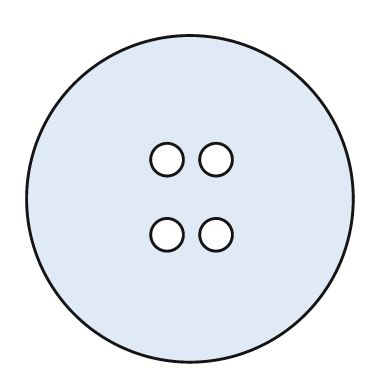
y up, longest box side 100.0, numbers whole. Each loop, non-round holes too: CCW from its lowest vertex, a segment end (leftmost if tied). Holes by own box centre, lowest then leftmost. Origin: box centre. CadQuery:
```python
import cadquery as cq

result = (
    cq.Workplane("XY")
    .moveTo(0.0, 0.0)
    .circle(50.0)
    .moveTo(-7.0, -11.0)
    .circle(5.0)
    .moveTo(8.0, -11.0)
    .circle(5.0)
    .moveTo(-7.0, 12.0)
    .circle(5.0)
    .moveTo(8.0, 12.0)
    .circle(5.0)
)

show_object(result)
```